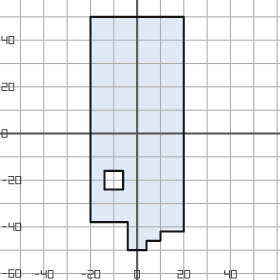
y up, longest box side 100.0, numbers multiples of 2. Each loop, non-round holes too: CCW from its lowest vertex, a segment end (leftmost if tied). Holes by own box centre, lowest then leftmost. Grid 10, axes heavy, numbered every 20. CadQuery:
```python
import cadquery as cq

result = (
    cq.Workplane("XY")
    .moveTo(-4.0, -50.0)
    .lineTo(4.0, -50.0)
    .lineTo(4.0, -46.0)
    .lineTo(10.0, -46.0)
    .lineTo(10.0, -42.0)
    .lineTo(20.0, -42.0)
    .lineTo(20.0, 50.0)
    .lineTo(-20.0, 50.0)
    .lineTo(-20.0, -38.0)
    .lineTo(-4.0, -38.0)
    .close()
    .moveTo(-14.0, -24.0)
    .lineTo(-6.0, -24.0)
    .lineTo(-6.0, -16.0)
    .lineTo(-14.0, -16.0)
    .close()
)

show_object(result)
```